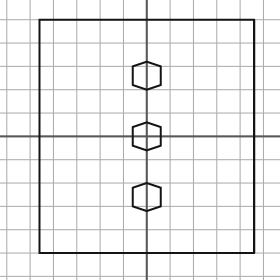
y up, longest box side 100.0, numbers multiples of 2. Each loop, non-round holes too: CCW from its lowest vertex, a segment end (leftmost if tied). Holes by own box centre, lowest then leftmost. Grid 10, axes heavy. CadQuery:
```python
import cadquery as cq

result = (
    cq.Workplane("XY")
    .moveTo(-46.0, -50.0)
    .lineTo(46.0, -50.0)
    .lineTo(46.0, 50.0)
    .lineTo(-46.0, 50.0)
    .close()
    .moveTo(0.0, -32.0)
    .lineTo(6.0, -30.0)
    .lineTo(6.0, -22.0)
    .lineTo(0.0, -20.0)
    .lineTo(-6.0, -22.0)
    .lineTo(-6.0, -30.0)
    .close()
    .moveTo(0.0, -6.0)
    .lineTo(6.0, -4.0)
    .lineTo(6.0, 4.0)
    .lineTo(0.0, 6.0)
    .lineTo(-6.0, 4.0)
    .lineTo(-6.0, -4.0)
    .close()
    .moveTo(0.0, 20.0)
    .lineTo(6.0, 22.0)
    .lineTo(6.0, 30.0)
    .lineTo(0.0, 32.0)
    .lineTo(-6.0, 30.0)
    .lineTo(-6.0, 22.0)
    .close()
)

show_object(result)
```